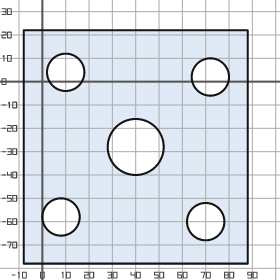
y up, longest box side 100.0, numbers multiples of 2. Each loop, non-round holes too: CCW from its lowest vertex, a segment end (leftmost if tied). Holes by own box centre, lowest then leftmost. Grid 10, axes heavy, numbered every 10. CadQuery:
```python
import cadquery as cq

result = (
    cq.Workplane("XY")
    .moveTo(-8.0, -78.0)
    .lineTo(88.0, -78.0)
    .lineTo(88.0, 22.0)
    .lineTo(-8.0, 22.0)
    .close()
    .moveTo(70.0, -60.0)
    .circle(8.0)
    .moveTo(8.0, -58.0)
    .circle(8.0)
    .moveTo(40.0, -28.0)
    .circle(12.0)
    .moveTo(72.0, 2.0)
    .circle(8.0)
    .moveTo(10.0, 4.0)
    .circle(8.0)
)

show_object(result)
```